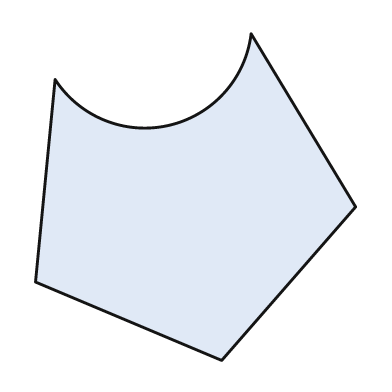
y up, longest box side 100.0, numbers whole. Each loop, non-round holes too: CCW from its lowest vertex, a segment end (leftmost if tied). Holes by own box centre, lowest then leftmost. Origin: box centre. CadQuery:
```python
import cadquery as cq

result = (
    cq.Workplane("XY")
    .moveTo(8.0, -50.0)
    .lineTo(49.0, -3.0)
    .lineTo(17.0, 50.0)
    .threePointArc((-8.0, 22.0), (-43.0, 36.0))
    .lineTo(-49.0, -26.0)
    .close()
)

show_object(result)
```